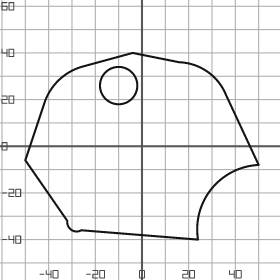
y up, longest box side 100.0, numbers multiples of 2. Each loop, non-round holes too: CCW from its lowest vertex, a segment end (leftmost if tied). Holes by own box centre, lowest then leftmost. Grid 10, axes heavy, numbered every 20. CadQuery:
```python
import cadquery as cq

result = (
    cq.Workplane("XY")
    .moveTo(24.0, -40.0)
    .threePointArc((30.0, -18.0), (50.0, -8.0))
    .lineTo(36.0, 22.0)
    .threePointArc((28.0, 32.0), (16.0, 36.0))
    .lineTo(-4.0, 40.0)
    .lineTo(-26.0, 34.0)
    .threePointArc((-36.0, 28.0), (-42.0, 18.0))
    .lineTo(-50.0, -6.0)
    .lineTo(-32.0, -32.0)
    .threePointArc((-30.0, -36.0), (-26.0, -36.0))
    .close()
    .moveTo(-10.0, 26.0)
    .circle(8.0)
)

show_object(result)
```